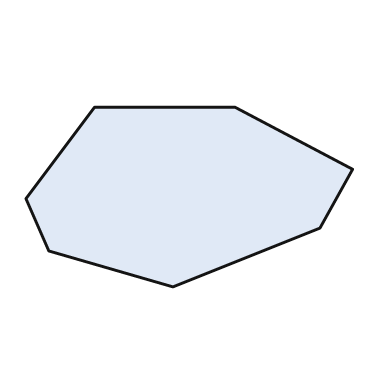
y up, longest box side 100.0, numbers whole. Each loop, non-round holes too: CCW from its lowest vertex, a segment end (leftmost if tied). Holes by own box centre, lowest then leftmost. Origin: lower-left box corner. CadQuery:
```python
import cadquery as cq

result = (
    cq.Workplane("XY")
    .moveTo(45.0, 0.0)
    .lineTo(90.0, 18.0)
    .lineTo(100.0, 36.0)
    .lineTo(64.0, 55.0)
    .lineTo(21.0, 55.0)
    .lineTo(0.0, 27.0)
    .lineTo(7.0, 11.0)
    .close()
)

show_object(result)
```